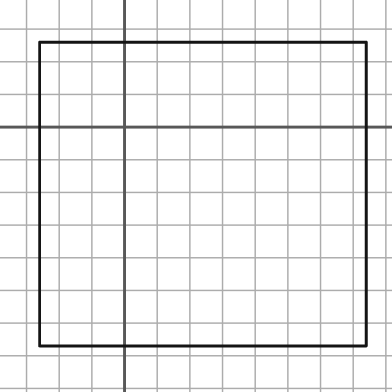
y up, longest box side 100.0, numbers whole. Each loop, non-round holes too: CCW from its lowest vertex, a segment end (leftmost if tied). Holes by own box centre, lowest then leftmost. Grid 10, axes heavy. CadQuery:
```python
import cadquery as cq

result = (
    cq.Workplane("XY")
    .moveTo(-26.0, -67.0)
    .lineTo(74.0, -67.0)
    .lineTo(74.0, 26.0)
    .lineTo(-26.0, 26.0)
    .close()
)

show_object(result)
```